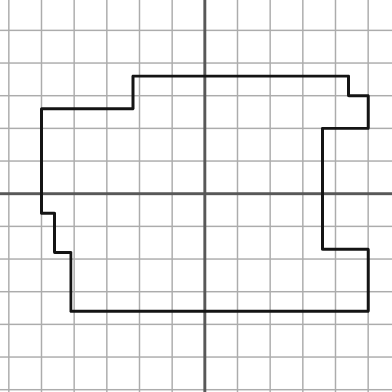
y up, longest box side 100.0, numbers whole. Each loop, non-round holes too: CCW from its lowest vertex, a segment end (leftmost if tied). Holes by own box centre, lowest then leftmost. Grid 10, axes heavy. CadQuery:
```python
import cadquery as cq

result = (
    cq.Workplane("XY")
    .moveTo(-41.0, -36.0)
    .lineTo(50.0, -36.0)
    .lineTo(50.0, -17.0)
    .lineTo(36.0, -17.0)
    .lineTo(36.0, 20.0)
    .lineTo(50.0, 20.0)
    .lineTo(50.0, 30.0)
    .lineTo(44.0, 30.0)
    .lineTo(44.0, 36.0)
    .lineTo(-22.0, 36.0)
    .lineTo(-22.0, 26.0)
    .lineTo(-50.0, 26.0)
    .lineTo(-50.0, -6.0)
    .lineTo(-46.0, -6.0)
    .lineTo(-46.0, -18.0)
    .lineTo(-41.0, -18.0)
    .close()
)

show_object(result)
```